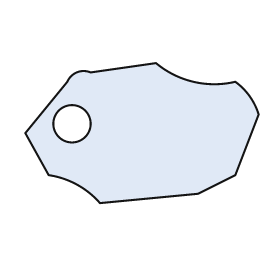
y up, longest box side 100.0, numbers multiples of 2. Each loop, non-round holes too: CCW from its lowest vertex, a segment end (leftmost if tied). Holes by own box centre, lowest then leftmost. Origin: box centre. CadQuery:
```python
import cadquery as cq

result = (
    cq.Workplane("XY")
    .moveTo(-18.0, -30.0)
    .lineTo(24.0, -26.0)
    .lineTo(40.0, -18.0)
    .lineTo(50.0, 8.0)
    .threePointArc((46.0, 16.0), (40.0, 22.0))
    .threePointArc((22.0, 22.0), (6.0, 30.0))
    .lineTo(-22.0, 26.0)
    .threePointArc((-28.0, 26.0), (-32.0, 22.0))
    .lineTo(-50.0, 0.0)
    .lineTo(-40.0, -18.0)
    .threePointArc((-28.0, -22.0), (-18.0, -30.0))
    .close()
    .moveTo(-30.0, 4.0)
    .circle(8.0)
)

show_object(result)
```